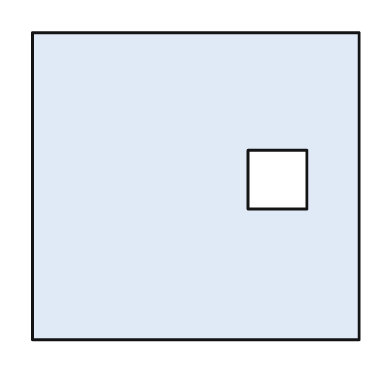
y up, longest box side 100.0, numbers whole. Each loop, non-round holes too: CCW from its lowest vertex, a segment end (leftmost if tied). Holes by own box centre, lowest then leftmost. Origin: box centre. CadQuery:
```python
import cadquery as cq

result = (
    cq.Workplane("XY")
    .moveTo(-50.0, -47.0)
    .lineTo(50.0, -47.0)
    .lineTo(50.0, 47.0)
    .lineTo(-50.0, 47.0)
    .close()
    .moveTo(16.0, -7.0)
    .lineTo(34.0, -7.0)
    .lineTo(34.0, 11.0)
    .lineTo(16.0, 11.0)
    .close()
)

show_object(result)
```